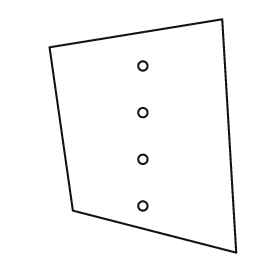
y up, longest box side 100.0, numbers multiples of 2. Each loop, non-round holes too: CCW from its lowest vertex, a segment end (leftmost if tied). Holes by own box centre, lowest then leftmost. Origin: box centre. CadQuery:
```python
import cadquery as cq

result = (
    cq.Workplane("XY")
    .moveTo(40.0, -50.0)
    .lineTo(34.0, 50.0)
    .lineTo(-40.0, 38.0)
    .lineTo(-30.0, -32.0)
    .close()
    .moveTo(0.0, -30.0)
    .circle(2.0)
    .moveTo(0.0, -10.0)
    .circle(2.0)
    .moveTo(0.0, 10.0)
    .circle(2.0)
    .moveTo(0.0, 30.0)
    .circle(2.0)
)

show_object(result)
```